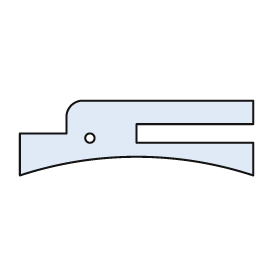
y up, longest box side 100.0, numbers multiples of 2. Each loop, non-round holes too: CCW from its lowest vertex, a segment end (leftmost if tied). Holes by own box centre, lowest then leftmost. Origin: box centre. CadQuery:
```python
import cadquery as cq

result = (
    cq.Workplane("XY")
    .moveTo(-50.0, -16.0)
    .threePointArc((0.0, -8.0), (50.0, -16.0))
    .lineTo(50.0, -2.0)
    .lineTo(0.0, -2.0)
    .lineTo(0.0, 6.0)
    .lineTo(50.0, 6.0)
    .lineTo(50.0, 16.0)
    .lineTo(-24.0, 16.0)
    .threePointArc((-28.0, 14.0), (-30.0, 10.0))
    .lineTo(-30.0, 2.0)
    .lineTo(-50.0, 2.0)
    .close()
    .moveTo(-20.0, 0.0)
    .circle(2.0)
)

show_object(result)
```